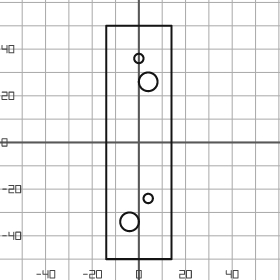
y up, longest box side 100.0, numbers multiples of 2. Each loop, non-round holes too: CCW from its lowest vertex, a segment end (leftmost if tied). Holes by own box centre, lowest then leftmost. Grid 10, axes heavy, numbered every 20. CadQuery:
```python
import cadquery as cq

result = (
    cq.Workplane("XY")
    .moveTo(-14.0, -50.0)
    .lineTo(14.0, -50.0)
    .lineTo(14.0, 50.0)
    .lineTo(-14.0, 50.0)
    .close()
    .moveTo(-4.0, -34.0)
    .circle(4.0)
    .moveTo(4.0, -24.0)
    .circle(2.0)
    .moveTo(4.0, 26.0)
    .circle(4.0)
    .moveTo(0.0, 36.0)
    .circle(2.0)
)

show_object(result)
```